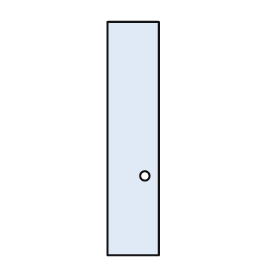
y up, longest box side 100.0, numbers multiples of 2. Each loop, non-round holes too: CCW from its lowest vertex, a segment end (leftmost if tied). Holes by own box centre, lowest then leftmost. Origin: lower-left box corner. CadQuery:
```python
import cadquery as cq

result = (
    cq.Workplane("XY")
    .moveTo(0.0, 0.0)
    .lineTo(22.0, 0.0)
    .lineTo(22.0, 100.0)
    .lineTo(0.0, 100.0)
    .close()
    .moveTo(16.0, 34.0)
    .circle(2.0)
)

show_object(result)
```